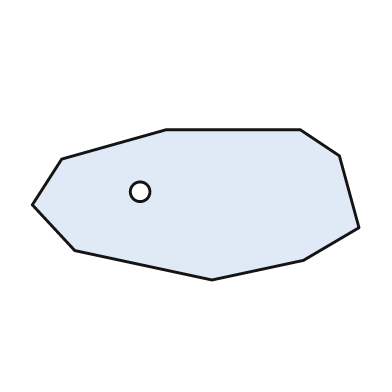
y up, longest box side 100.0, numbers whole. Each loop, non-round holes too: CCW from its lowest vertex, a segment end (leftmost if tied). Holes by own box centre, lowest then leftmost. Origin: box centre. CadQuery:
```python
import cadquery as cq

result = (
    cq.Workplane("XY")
    .moveTo(5.0, -23.0)
    .lineTo(33.0, -17.0)
    .lineTo(50.0, -7.0)
    .lineTo(44.0, 15.0)
    .lineTo(32.0, 23.0)
    .lineTo(-9.0, 23.0)
    .lineTo(-41.0, 14.0)
    .lineTo(-50.0, 0.0)
    .lineTo(-37.0, -14.0)
    .close()
    .moveTo(-17.0, 4.0)
    .circle(3.0)
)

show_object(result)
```